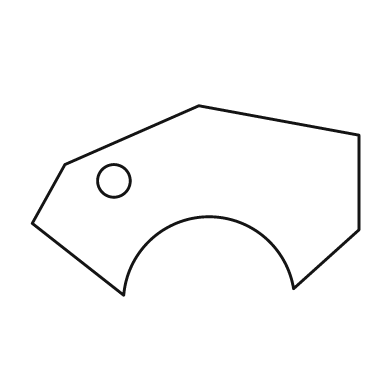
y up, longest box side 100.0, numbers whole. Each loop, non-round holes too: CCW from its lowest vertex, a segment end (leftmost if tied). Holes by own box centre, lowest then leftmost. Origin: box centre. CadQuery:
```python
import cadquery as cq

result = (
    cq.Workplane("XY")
    .moveTo(-22.0, -29.0)
    .threePointArc((3.0, -5.0), (30.0, -27.0))
    .lineTo(50.0, -9.0)
    .lineTo(50.0, 20.0)
    .lineTo(1.0, 29.0)
    .lineTo(-40.0, 11.0)
    .lineTo(-50.0, -7.0)
    .close()
    .moveTo(-25.0, 6.0)
    .circle(5.0)
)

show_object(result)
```